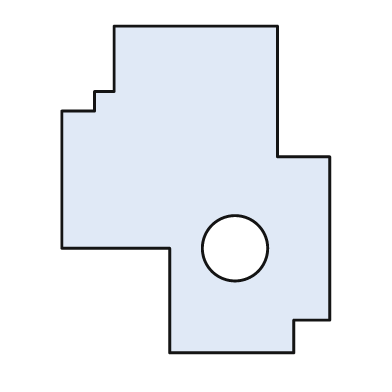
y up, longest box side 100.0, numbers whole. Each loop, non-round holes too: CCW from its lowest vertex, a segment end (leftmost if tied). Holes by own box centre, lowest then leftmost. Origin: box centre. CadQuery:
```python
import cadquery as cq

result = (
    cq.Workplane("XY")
    .moveTo(-8.0, -50.0)
    .lineTo(30.0, -50.0)
    .lineTo(30.0, -40.0)
    .lineTo(41.0, -40.0)
    .lineTo(41.0, 10.0)
    .lineTo(25.0, 10.0)
    .lineTo(25.0, 50.0)
    .lineTo(-25.0, 50.0)
    .lineTo(-25.0, 30.0)
    .lineTo(-31.0, 30.0)
    .lineTo(-31.0, 24.0)
    .lineTo(-41.0, 24.0)
    .lineTo(-41.0, -18.0)
    .lineTo(-8.0, -18.0)
    .close()
    .moveTo(12.0, -18.0)
    .circle(10.0)
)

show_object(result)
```